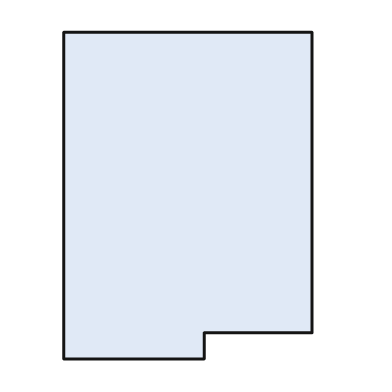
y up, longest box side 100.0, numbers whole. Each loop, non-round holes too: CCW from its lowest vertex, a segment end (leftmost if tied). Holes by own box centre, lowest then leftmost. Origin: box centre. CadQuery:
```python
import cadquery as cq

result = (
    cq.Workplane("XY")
    .moveTo(-38.0, -50.0)
    .lineTo(5.0, -50.0)
    .lineTo(5.0, -42.0)
    .lineTo(38.0, -42.0)
    .lineTo(38.0, 50.0)
    .lineTo(-38.0, 50.0)
    .close()
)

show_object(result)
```